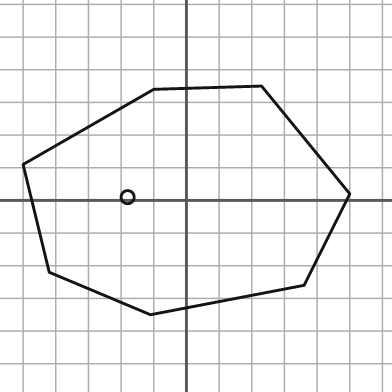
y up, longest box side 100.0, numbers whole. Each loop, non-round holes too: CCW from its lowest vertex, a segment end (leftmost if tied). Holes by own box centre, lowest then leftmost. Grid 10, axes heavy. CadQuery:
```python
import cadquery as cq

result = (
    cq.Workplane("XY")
    .moveTo(-11.0, -35.0)
    .lineTo(36.0, -26.0)
    .lineTo(50.0, 2.0)
    .lineTo(23.0, 35.0)
    .lineTo(-10.0, 34.0)
    .lineTo(-50.0, 11.0)
    .lineTo(-42.0, -22.0)
    .close()
    .moveTo(-18.0, 1.0)
    .circle(2.0)
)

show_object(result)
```